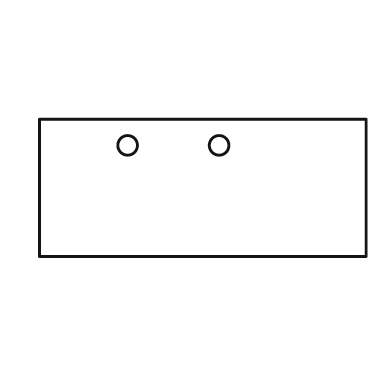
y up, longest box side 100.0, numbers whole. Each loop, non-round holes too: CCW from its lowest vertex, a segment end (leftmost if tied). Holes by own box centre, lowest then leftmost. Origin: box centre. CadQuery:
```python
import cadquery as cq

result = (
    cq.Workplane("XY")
    .moveTo(-50.0, -21.0)
    .lineTo(50.0, -21.0)
    .lineTo(50.0, 21.0)
    .lineTo(-50.0, 21.0)
    .close()
    .moveTo(-23.0, 13.0)
    .circle(3.0)
    .moveTo(5.0, 13.0)
    .circle(3.0)
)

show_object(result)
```